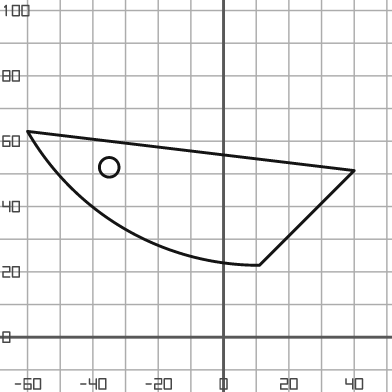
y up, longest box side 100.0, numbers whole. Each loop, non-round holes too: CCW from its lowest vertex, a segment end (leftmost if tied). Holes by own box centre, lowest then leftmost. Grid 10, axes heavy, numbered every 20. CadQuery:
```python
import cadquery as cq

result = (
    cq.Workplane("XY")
    .moveTo(11.0, 22.0)
    .lineTo(40.0, 51.0)
    .lineTo(-60.0, 63.0)
    .threePointArc((-30.0, 33.0), (11.0, 22.0))
    .close()
    .moveTo(-35.0, 52.0)
    .circle(3.0)
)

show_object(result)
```